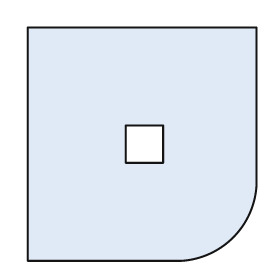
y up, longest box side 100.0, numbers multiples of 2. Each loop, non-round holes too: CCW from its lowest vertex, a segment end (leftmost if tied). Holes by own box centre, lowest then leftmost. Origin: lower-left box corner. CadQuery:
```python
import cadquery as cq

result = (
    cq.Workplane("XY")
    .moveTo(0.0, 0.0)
    .lineTo(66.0, 0.0)
    .threePointArc((88.0, 10.0), (98.0, 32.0))
    .lineTo(98.0, 100.0)
    .lineTo(0.0, 100.0)
    .close()
    .moveTo(42.0, 42.0)
    .lineTo(58.0, 42.0)
    .lineTo(58.0, 58.0)
    .lineTo(42.0, 58.0)
    .close()
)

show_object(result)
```